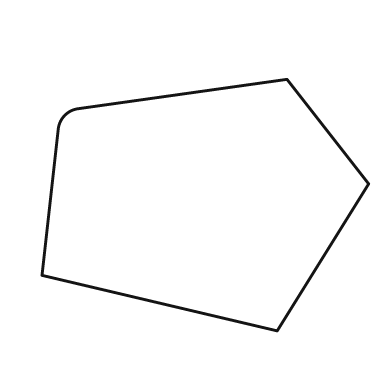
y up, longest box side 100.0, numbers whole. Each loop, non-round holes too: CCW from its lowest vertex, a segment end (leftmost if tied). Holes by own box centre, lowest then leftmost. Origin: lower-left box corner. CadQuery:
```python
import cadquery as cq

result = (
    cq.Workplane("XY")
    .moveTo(72.0, 0.0)
    .lineTo(100.0, 45.0)
    .lineTo(75.0, 77.0)
    .lineTo(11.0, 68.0)
    .threePointArc((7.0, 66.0), (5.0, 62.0))
    .lineTo(0.0, 17.0)
    .close()
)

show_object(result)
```